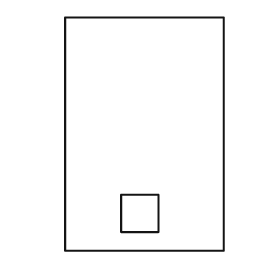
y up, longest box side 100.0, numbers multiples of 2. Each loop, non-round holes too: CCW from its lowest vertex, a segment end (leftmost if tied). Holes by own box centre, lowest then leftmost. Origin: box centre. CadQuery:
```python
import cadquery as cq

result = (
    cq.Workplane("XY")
    .moveTo(-34.0, -50.0)
    .lineTo(34.0, -50.0)
    .lineTo(34.0, 50.0)
    .lineTo(-34.0, 50.0)
    .close()
    .moveTo(-10.0, -42.0)
    .lineTo(6.0, -42.0)
    .lineTo(6.0, -26.0)
    .lineTo(-10.0, -26.0)
    .close()
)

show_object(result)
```